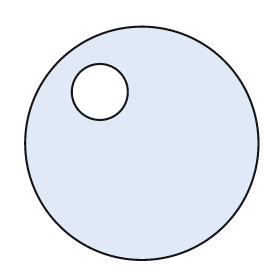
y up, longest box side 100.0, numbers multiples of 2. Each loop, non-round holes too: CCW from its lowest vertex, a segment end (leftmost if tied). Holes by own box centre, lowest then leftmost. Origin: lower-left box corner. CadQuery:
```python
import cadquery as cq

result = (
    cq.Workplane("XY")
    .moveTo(50.0, 50.0)
    .circle(50.0)
    .moveTo(32.0, 72.0)
    .circle(12.0)
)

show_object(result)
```